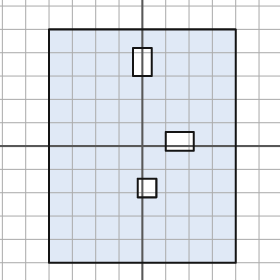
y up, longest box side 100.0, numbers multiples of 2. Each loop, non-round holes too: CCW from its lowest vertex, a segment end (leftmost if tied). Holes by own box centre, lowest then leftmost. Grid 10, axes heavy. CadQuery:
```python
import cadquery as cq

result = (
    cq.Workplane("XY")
    .moveTo(-40.0, -50.0)
    .lineTo(40.0, -50.0)
    .lineTo(40.0, 50.0)
    .lineTo(-40.0, 50.0)
    .close()
    .moveTo(-2.0, -22.0)
    .lineTo(6.0, -22.0)
    .lineTo(6.0, -14.0)
    .lineTo(-2.0, -14.0)
    .close()
    .moveTo(10.0, -2.0)
    .lineTo(22.0, -2.0)
    .lineTo(22.0, 6.0)
    .lineTo(10.0, 6.0)
    .close()
    .moveTo(-4.0, 30.0)
    .lineTo(4.0, 30.0)
    .lineTo(4.0, 42.0)
    .lineTo(-4.0, 42.0)
    .close()
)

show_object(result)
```